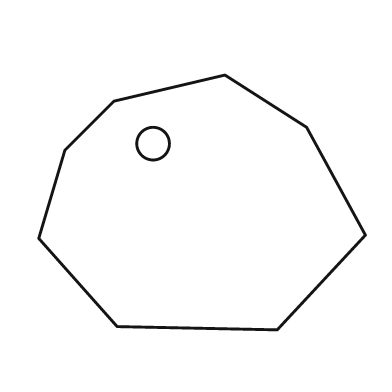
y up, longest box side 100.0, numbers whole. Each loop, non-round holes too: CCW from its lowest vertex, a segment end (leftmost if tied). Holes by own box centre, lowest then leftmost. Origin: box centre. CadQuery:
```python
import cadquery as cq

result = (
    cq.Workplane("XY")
    .moveTo(23.0, -39.0)
    .lineTo(50.0, -10.0)
    .lineTo(32.0, 23.0)
    .lineTo(7.0, 39.0)
    .lineTo(-27.0, 31.0)
    .lineTo(-42.0, 16.0)
    .lineTo(-50.0, -11.0)
    .lineTo(-26.0, -38.0)
    .close()
    .moveTo(-15.0, 18.0)
    .circle(5.0)
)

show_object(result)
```